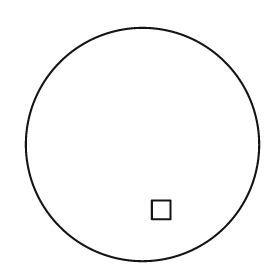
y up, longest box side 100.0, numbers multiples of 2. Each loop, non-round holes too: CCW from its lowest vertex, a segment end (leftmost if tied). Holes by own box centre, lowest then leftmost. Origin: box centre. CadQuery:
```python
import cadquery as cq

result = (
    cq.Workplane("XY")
    .moveTo(0.0, 0.0)
    .circle(50.0)
    .moveTo(4.0, -32.0)
    .lineTo(12.0, -32.0)
    .lineTo(12.0, -24.0)
    .lineTo(4.0, -24.0)
    .close()
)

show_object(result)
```